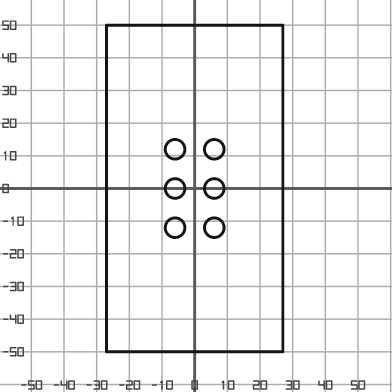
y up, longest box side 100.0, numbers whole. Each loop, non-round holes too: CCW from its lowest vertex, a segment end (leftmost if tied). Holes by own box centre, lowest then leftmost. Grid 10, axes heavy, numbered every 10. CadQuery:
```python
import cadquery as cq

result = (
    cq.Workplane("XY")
    .moveTo(-27.0, -50.0)
    .lineTo(27.0, -50.0)
    .lineTo(27.0, 50.0)
    .lineTo(-27.0, 50.0)
    .close()
    .moveTo(-6.0, -12.0)
    .circle(3.0)
    .moveTo(6.0, -12.0)
    .circle(3.0)
    .moveTo(-6.0, 0.0)
    .circle(3.0)
    .moveTo(6.0, 0.0)
    .circle(3.0)
    .moveTo(-6.0, 12.0)
    .circle(3.0)
    .moveTo(6.0, 12.0)
    .circle(3.0)
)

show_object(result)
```